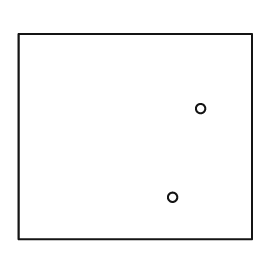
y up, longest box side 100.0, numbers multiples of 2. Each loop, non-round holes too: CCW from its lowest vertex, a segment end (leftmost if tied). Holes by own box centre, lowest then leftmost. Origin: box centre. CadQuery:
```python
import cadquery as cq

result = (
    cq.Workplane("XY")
    .moveTo(-50.0, -44.0)
    .lineTo(50.0, -44.0)
    .lineTo(50.0, 44.0)
    .lineTo(-50.0, 44.0)
    .close()
    .moveTo(16.0, -26.0)
    .circle(2.0)
    .moveTo(28.0, 12.0)
    .circle(2.0)
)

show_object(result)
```